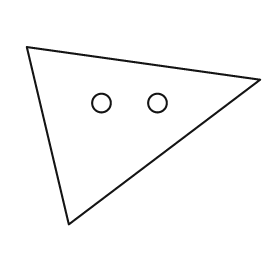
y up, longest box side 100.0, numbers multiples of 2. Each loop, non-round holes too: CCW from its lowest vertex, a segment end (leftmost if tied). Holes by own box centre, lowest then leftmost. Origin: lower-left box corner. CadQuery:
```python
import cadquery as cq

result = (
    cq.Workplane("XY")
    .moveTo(18.0, 0.0)
    .lineTo(100.0, 62.0)
    .lineTo(0.0, 76.0)
    .close()
    .moveTo(32.0, 52.0)
    .circle(4.0)
    .moveTo(56.0, 52.0)
    .circle(4.0)
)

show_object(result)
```